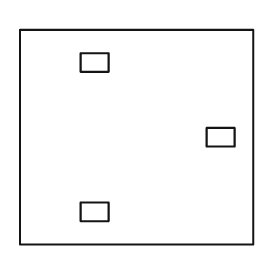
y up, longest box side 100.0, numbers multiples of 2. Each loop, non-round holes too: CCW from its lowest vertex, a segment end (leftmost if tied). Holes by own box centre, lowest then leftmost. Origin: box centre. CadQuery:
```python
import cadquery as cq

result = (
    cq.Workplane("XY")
    .moveTo(-50.0, -46.0)
    .lineTo(50.0, -46.0)
    .lineTo(50.0, 46.0)
    .lineTo(-50.0, 46.0)
    .close()
    .moveTo(-24.0, -36.0)
    .lineTo(-12.0, -36.0)
    .lineTo(-12.0, -28.0)
    .lineTo(-24.0, -28.0)
    .close()
    .moveTo(30.0, -4.0)
    .lineTo(42.0, -4.0)
    .lineTo(42.0, 4.0)
    .lineTo(30.0, 4.0)
    .close()
    .moveTo(-24.0, 28.0)
    .lineTo(-12.0, 28.0)
    .lineTo(-12.0, 36.0)
    .lineTo(-24.0, 36.0)
    .close()
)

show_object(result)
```